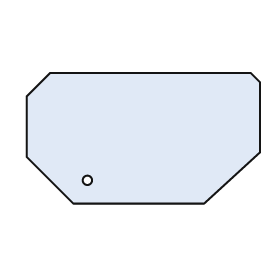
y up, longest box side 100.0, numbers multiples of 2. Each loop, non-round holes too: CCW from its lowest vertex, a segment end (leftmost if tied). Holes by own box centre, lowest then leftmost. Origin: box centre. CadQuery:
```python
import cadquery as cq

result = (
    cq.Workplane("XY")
    .moveTo(-30.0, -28.0)
    .lineTo(26.0, -28.0)
    .lineTo(50.0, -6.0)
    .lineTo(50.0, 24.0)
    .lineTo(46.0, 28.0)
    .lineTo(-40.0, 28.0)
    .lineTo(-50.0, 18.0)
    .lineTo(-50.0, -8.0)
    .close()
    .moveTo(-24.0, -18.0)
    .circle(2.0)
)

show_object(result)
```